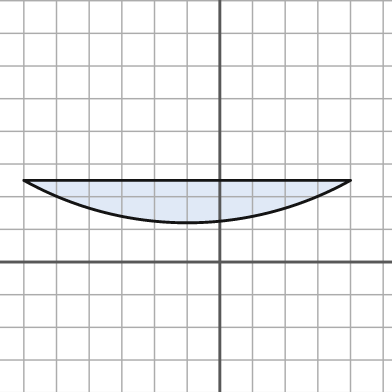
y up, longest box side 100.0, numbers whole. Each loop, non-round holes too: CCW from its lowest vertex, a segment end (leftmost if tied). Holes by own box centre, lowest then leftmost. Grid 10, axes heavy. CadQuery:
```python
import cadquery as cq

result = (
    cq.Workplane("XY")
    .moveTo(-60.0, 25.0)
    .threePointArc((-10.0, 12.0), (40.0, 25.0))
    .close()
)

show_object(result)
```